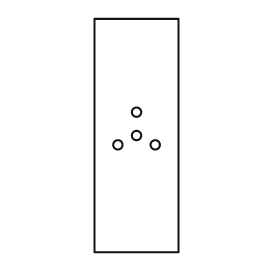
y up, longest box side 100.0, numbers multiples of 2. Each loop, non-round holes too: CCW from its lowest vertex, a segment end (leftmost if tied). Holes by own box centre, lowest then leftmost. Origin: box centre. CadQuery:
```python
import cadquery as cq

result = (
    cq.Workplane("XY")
    .moveTo(-18.0, -50.0)
    .lineTo(18.0, -50.0)
    .lineTo(18.0, 50.0)
    .lineTo(-18.0, 50.0)
    .close()
    .moveTo(-8.0, -4.0)
    .circle(2.0)
    .moveTo(8.0, -4.0)
    .circle(2.0)
    .moveTo(0.0, 0.0)
    .circle(2.0)
    .moveTo(0.0, 10.0)
    .circle(2.0)
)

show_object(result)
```